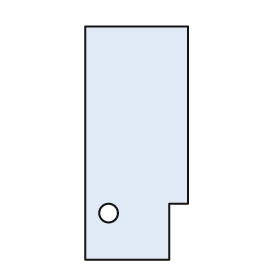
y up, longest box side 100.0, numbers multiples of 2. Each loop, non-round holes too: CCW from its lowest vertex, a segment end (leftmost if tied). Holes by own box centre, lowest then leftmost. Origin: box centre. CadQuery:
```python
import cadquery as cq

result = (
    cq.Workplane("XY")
    .moveTo(-22.0, -50.0)
    .lineTo(14.0, -50.0)
    .lineTo(14.0, -26.0)
    .lineTo(22.0, -26.0)
    .lineTo(22.0, 50.0)
    .lineTo(-22.0, 50.0)
    .close()
    .moveTo(-12.0, -30.0)
    .circle(4.0)
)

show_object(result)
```